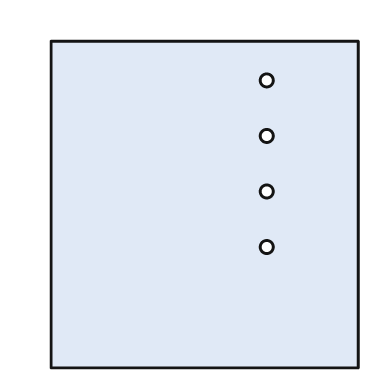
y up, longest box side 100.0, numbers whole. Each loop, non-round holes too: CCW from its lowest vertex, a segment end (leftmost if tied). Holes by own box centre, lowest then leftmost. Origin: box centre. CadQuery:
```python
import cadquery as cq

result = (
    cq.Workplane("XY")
    .moveTo(-47.0, -50.0)
    .lineTo(47.0, -50.0)
    .lineTo(47.0, 50.0)
    .lineTo(-47.0, 50.0)
    .close()
    .moveTo(19.0, -13.0)
    .circle(2.0)
    .moveTo(19.0, 4.0)
    .circle(2.0)
    .moveTo(19.0, 21.0)
    .circle(2.0)
    .moveTo(19.0, 38.0)
    .circle(2.0)
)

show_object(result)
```